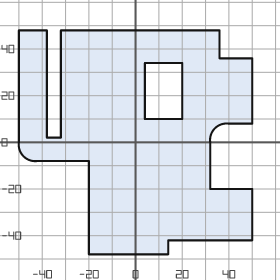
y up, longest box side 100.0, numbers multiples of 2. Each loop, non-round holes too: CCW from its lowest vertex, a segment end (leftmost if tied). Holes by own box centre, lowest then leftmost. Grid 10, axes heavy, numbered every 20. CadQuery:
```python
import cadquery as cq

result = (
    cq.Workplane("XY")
    .moveTo(-20.0, -48.0)
    .lineTo(14.0, -48.0)
    .lineTo(14.0, -42.0)
    .lineTo(50.0, -42.0)
    .lineTo(50.0, -20.0)
    .lineTo(32.0, -20.0)
    .lineTo(32.0, 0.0)
    .threePointArc((34.0, 6.0), (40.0, 8.0))
    .lineTo(50.0, 8.0)
    .lineTo(50.0, 36.0)
    .lineTo(36.0, 36.0)
    .lineTo(36.0, 48.0)
    .lineTo(-32.0, 48.0)
    .lineTo(-32.0, 2.0)
    .lineTo(-38.0, 2.0)
    .lineTo(-38.0, 48.0)
    .lineTo(-50.0, 48.0)
    .lineTo(-50.0, 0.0)
    .threePointArc((-48.0, -6.0), (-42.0, -8.0))
    .lineTo(-20.0, -8.0)
    .close()
    .moveTo(4.0, 10.0)
    .lineTo(20.0, 10.0)
    .lineTo(20.0, 34.0)
    .lineTo(4.0, 34.0)
    .close()
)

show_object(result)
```